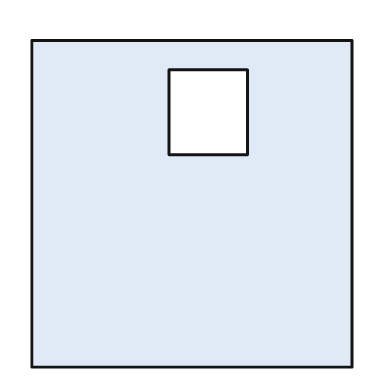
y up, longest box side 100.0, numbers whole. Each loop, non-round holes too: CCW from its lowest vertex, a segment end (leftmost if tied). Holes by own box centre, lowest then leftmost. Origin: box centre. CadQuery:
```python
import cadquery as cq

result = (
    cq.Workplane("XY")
    .moveTo(-49.0, -50.0)
    .lineTo(49.0, -50.0)
    .lineTo(49.0, 50.0)
    .lineTo(-49.0, 50.0)
    .close()
    .moveTo(-7.0, 15.0)
    .lineTo(17.0, 15.0)
    .lineTo(17.0, 41.0)
    .lineTo(-7.0, 41.0)
    .close()
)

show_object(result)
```